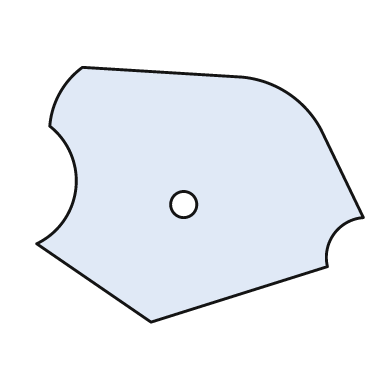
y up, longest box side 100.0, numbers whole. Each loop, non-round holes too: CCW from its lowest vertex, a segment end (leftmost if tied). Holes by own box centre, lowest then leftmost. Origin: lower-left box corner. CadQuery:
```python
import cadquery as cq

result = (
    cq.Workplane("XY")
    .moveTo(35.0, 0.0)
    .lineTo(89.0, 17.0)
    .threePointArc((91.0, 27.0), (100.0, 32.0))
    .lineTo(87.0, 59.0)
    .threePointArc((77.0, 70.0), (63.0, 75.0))
    .lineTo(14.0, 78.0)
    .threePointArc((7.0, 70.0), (4.0, 60.0))
    .threePointArc((12.0, 41.0), (0.0, 24.0))
    .close()
    .moveTo(45.0, 36.0)
    .circle(4.0)
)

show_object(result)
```